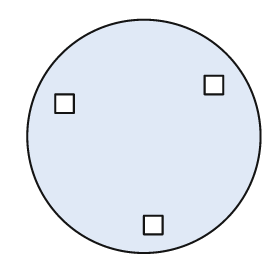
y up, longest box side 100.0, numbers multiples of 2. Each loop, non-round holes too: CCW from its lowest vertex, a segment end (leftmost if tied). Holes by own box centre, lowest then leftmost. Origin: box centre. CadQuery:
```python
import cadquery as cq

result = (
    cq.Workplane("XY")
    .moveTo(0.0, 0.0)
    .circle(50.0)
    .moveTo(0.0, -42.0)
    .lineTo(8.0, -42.0)
    .lineTo(8.0, -34.0)
    .lineTo(0.0, -34.0)
    .close()
    .moveTo(-38.0, 10.0)
    .lineTo(-30.0, 10.0)
    .lineTo(-30.0, 18.0)
    .lineTo(-38.0, 18.0)
    .close()
    .moveTo(26.0, 18.0)
    .lineTo(34.0, 18.0)
    .lineTo(34.0, 26.0)
    .lineTo(26.0, 26.0)
    .close()
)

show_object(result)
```